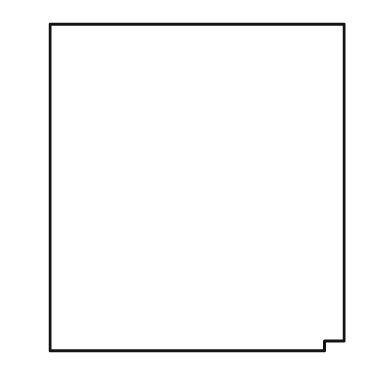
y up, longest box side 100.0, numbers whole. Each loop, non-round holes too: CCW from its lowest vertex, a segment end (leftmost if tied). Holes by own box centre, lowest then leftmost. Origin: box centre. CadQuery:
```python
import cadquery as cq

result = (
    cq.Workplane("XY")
    .moveTo(-45.0, -50.0)
    .lineTo(39.0, -50.0)
    .lineTo(39.0, -47.0)
    .lineTo(45.0, -47.0)
    .lineTo(45.0, 50.0)
    .lineTo(-45.0, 50.0)
    .close()
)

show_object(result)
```